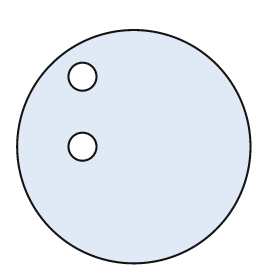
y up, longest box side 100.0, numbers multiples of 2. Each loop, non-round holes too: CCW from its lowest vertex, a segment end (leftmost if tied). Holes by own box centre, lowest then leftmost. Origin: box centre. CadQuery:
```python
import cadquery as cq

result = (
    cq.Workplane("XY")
    .moveTo(0.0, 0.0)
    .circle(50.0)
    .moveTo(-22.0, 0.0)
    .circle(6.0)
    .moveTo(-22.0, 30.0)
    .circle(6.0)
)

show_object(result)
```